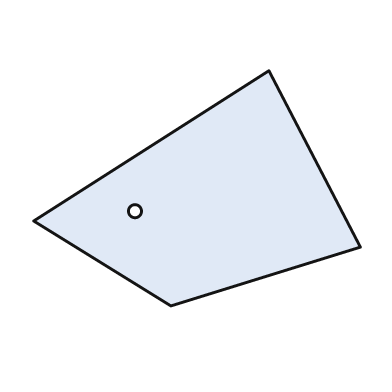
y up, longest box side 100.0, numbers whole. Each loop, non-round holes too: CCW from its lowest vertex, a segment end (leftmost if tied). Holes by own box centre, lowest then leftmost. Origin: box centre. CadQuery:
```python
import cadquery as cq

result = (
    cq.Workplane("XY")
    .moveTo(-8.0, -36.0)
    .lineTo(50.0, -18.0)
    .lineTo(22.0, 36.0)
    .lineTo(-50.0, -10.0)
    .close()
    .moveTo(-19.0, -7.0)
    .circle(2.0)
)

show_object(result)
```